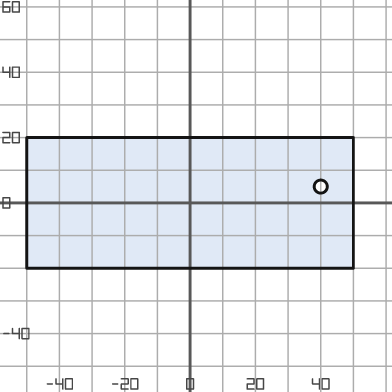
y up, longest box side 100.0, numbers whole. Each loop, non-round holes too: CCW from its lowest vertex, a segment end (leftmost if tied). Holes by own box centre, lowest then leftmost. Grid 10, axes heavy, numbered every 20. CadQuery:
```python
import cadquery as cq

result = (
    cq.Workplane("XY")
    .moveTo(-50.0, -20.0)
    .lineTo(50.0, -20.0)
    .lineTo(50.0, 20.0)
    .lineTo(-50.0, 20.0)
    .close()
    .moveTo(40.0, 5.0)
    .circle(2.0)
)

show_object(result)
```